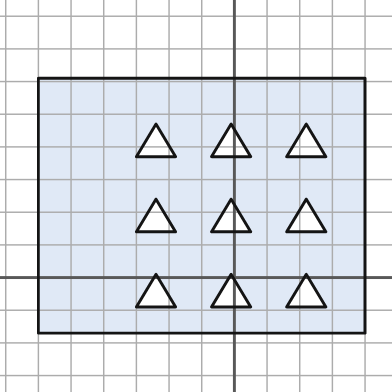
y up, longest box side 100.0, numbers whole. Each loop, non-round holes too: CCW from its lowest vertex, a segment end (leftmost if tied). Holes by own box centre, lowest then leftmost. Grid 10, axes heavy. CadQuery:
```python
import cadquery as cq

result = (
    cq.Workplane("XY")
    .moveTo(-60.0, -17.0)
    .lineTo(40.0, -17.0)
    .lineTo(40.0, 61.0)
    .lineTo(-60.0, 61.0)
    .close()
    .moveTo(-30.0, -9.0)
    .lineTo(-18.0, -9.0)
    .lineTo(-24.0, 1.0)
    .close()
    .moveTo(-7.0, -9.0)
    .lineTo(5.0, -9.0)
    .lineTo(-1.0, 1.0)
    .close()
    .moveTo(16.0, -9.0)
    .lineTo(28.0, -9.0)
    .lineTo(22.0, 1.0)
    .close()
    .moveTo(-30.0, 14.0)
    .lineTo(-18.0, 14.0)
    .lineTo(-24.0, 24.0)
    .close()
    .moveTo(-7.0, 14.0)
    .lineTo(5.0, 14.0)
    .lineTo(-1.0, 24.0)
    .close()
    .moveTo(16.0, 14.0)
    .lineTo(28.0, 14.0)
    .lineTo(22.0, 24.0)
    .close()
    .moveTo(-30.0, 37.0)
    .lineTo(-18.0, 37.0)
    .lineTo(-24.0, 47.0)
    .close()
    .moveTo(-7.0, 37.0)
    .lineTo(5.0, 37.0)
    .lineTo(-1.0, 47.0)
    .close()
    .moveTo(16.0, 37.0)
    .lineTo(28.0, 37.0)
    .lineTo(22.0, 47.0)
    .close()
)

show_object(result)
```